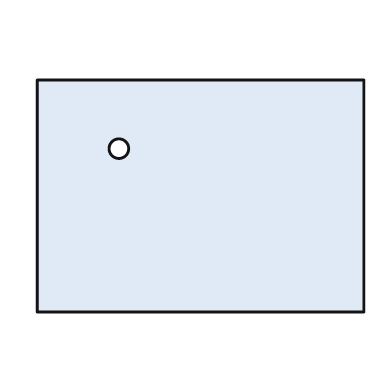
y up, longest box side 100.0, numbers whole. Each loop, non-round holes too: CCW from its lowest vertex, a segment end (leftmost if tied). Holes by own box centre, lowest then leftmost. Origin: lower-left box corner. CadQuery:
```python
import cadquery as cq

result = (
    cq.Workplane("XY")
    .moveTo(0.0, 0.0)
    .lineTo(100.0, 0.0)
    .lineTo(100.0, 71.0)
    .lineTo(0.0, 71.0)
    .close()
    .moveTo(25.0, 50.0)
    .circle(3.0)
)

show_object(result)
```